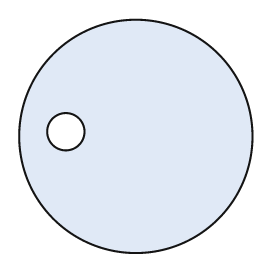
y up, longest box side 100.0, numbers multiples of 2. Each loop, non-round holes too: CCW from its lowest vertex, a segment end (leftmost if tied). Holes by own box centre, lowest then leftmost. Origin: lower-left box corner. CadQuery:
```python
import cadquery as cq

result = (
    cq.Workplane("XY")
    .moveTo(50.0, 50.0)
    .circle(50.0)
    .moveTo(20.0, 52.0)
    .circle(8.0)
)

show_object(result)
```